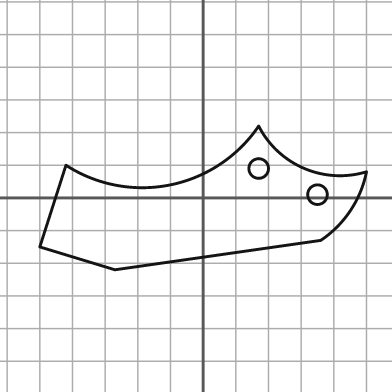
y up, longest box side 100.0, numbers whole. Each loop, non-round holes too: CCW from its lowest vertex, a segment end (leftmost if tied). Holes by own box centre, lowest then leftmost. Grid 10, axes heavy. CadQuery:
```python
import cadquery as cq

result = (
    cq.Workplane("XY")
    .moveTo(-27.0, -22.0)
    .lineTo(36.0, -13.0)
    .threePointArc((45.0, -4.0), (50.0, 8.0))
    .threePointArc((31.0, 9.0), (17.0, 22.0))
    .threePointArc((-10.0, 4.0), (-42.0, 10.0))
    .lineTo(-50.0, -15.0)
    .close()
    .moveTo(35.0, 1.0)
    .circle(3.0)
    .moveTo(17.0, 9.0)
    .circle(3.0)
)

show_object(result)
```